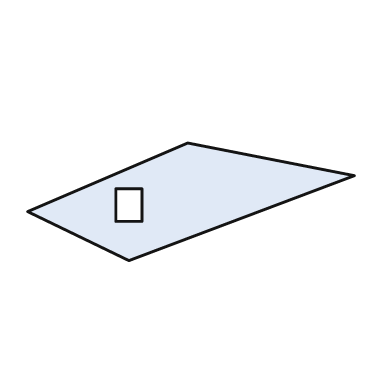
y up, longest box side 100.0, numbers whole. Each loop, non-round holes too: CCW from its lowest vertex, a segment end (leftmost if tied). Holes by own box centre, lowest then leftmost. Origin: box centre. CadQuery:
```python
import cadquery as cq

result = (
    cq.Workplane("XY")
    .moveTo(-19.0, -18.0)
    .lineTo(50.0, 8.0)
    .lineTo(-1.0, 18.0)
    .lineTo(-50.0, -3.0)
    .close()
    .moveTo(-23.0, -6.0)
    .lineTo(-15.0, -6.0)
    .lineTo(-15.0, 4.0)
    .lineTo(-23.0, 4.0)
    .close()
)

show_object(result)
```